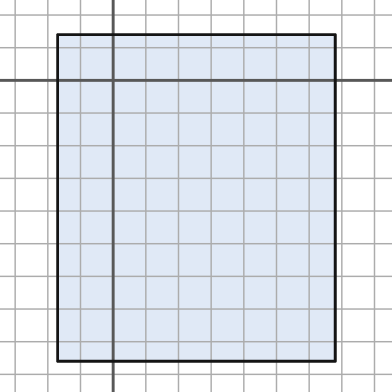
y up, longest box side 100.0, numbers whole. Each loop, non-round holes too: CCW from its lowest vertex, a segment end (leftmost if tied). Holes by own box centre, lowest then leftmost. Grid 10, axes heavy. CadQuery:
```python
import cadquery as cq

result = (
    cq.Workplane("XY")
    .moveTo(-17.0, -86.0)
    .lineTo(68.0, -86.0)
    .lineTo(68.0, 14.0)
    .lineTo(-17.0, 14.0)
    .close()
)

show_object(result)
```